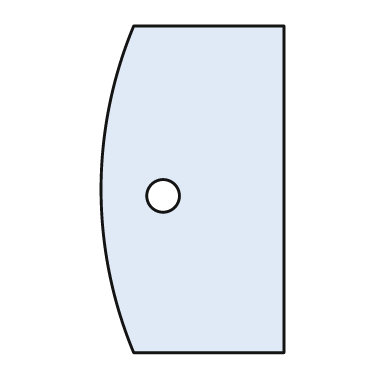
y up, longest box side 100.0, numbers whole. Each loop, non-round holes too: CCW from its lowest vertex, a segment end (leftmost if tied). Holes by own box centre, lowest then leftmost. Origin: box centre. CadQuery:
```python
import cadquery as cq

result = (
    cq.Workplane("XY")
    .moveTo(-18.0, -50.0)
    .lineTo(28.0, -50.0)
    .lineTo(28.0, 50.0)
    .lineTo(-18.0, 50.0)
    .threePointArc((-28.0, 0.0), (-18.0, -50.0))
    .close()
    .moveTo(-9.0, -2.0)
    .circle(5.0)
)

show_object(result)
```